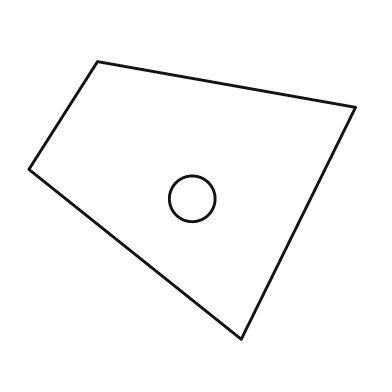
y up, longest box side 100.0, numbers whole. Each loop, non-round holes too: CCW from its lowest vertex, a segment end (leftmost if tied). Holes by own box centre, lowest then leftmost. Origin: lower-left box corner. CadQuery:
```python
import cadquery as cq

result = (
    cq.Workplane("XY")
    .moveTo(65.0, 0.0)
    .lineTo(100.0, 71.0)
    .lineTo(21.0, 85.0)
    .lineTo(0.0, 52.0)
    .close()
    .moveTo(50.0, 43.0)
    .circle(7.0)
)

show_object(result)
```